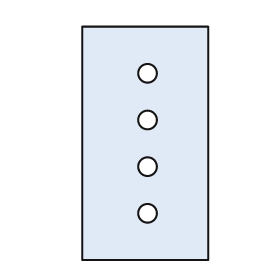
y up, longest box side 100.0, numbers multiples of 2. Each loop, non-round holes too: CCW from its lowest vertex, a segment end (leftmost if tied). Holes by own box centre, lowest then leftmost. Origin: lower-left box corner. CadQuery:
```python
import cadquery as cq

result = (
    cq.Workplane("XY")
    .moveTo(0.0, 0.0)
    .lineTo(54.0, 0.0)
    .lineTo(54.0, 100.0)
    .lineTo(0.0, 100.0)
    .close()
    .moveTo(28.0, 20.0)
    .circle(4.0)
    .moveTo(28.0, 40.0)
    .circle(4.0)
    .moveTo(28.0, 60.0)
    .circle(4.0)
    .moveTo(28.0, 80.0)
    .circle(4.0)
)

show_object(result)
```